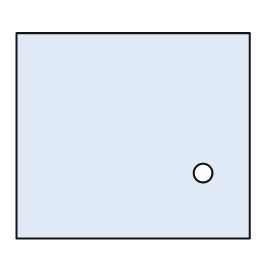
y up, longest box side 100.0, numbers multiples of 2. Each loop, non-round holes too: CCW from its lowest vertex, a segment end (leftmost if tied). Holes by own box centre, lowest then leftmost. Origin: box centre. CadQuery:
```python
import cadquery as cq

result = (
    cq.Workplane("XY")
    .moveTo(-50.0, -44.0)
    .lineTo(50.0, -44.0)
    .lineTo(50.0, 44.0)
    .lineTo(-50.0, 44.0)
    .close()
    .moveTo(30.0, -16.0)
    .circle(4.0)
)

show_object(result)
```